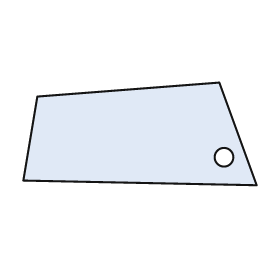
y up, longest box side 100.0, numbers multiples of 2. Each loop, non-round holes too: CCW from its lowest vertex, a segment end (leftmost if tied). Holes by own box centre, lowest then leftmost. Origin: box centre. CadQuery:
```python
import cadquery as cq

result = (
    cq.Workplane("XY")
    .moveTo(50.0, -22.0)
    .lineTo(34.0, 22.0)
    .lineTo(-44.0, 16.0)
    .lineTo(-50.0, -20.0)
    .close()
    .moveTo(36.0, -10.0)
    .circle(4.0)
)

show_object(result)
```